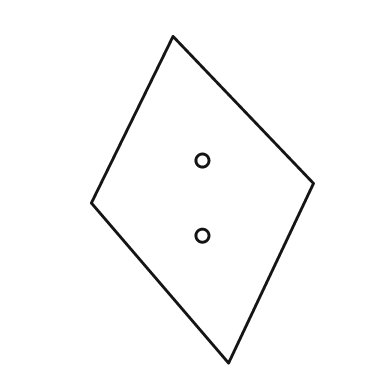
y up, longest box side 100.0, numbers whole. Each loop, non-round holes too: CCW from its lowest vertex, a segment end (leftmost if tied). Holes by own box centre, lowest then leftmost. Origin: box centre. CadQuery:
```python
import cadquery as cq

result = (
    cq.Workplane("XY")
    .moveTo(8.0, -50.0)
    .lineTo(34.0, 5.0)
    .lineTo(-9.0, 50.0)
    .lineTo(-34.0, -1.0)
    .close()
    .moveTo(0.0, -11.0)
    .circle(2.0)
    .moveTo(0.0, 12.0)
    .circle(2.0)
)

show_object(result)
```